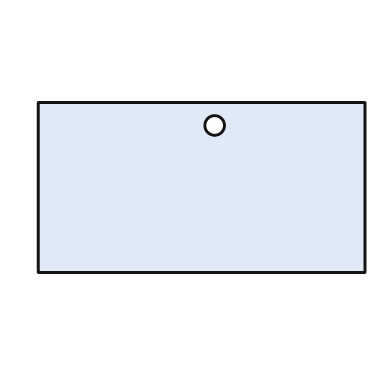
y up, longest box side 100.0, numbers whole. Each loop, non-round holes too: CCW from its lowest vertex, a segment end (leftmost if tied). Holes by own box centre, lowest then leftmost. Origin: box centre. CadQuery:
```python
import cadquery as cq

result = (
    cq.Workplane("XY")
    .moveTo(-50.0, -26.0)
    .lineTo(50.0, -26.0)
    .lineTo(50.0, 26.0)
    .lineTo(-50.0, 26.0)
    .close()
    .moveTo(4.0, 19.0)
    .circle(3.0)
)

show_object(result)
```